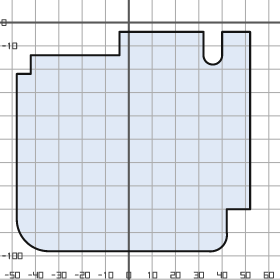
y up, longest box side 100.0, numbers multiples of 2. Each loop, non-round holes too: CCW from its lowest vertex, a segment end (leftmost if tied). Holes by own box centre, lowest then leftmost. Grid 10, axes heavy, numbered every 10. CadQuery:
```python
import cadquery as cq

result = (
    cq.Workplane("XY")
    .moveTo(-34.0, -98.0)
    .lineTo(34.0, -98.0)
    .threePointArc((40.0, -96.0), (42.0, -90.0))
    .lineTo(42.0, -80.0)
    .lineTo(52.0, -80.0)
    .lineTo(52.0, -4.0)
    .lineTo(40.0, -4.0)
    .lineTo(40.0, -14.0)
    .threePointArc((36.0, -18.0), (32.0, -14.0))
    .lineTo(32.0, -4.0)
    .lineTo(-4.0, -4.0)
    .lineTo(-4.0, -14.0)
    .lineTo(-42.0, -14.0)
    .lineTo(-42.0, -22.0)
    .lineTo(-48.0, -22.0)
    .lineTo(-48.0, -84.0)
    .threePointArc((-44.0, -94.0), (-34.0, -98.0))
    .close()
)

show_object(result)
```